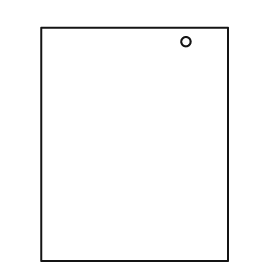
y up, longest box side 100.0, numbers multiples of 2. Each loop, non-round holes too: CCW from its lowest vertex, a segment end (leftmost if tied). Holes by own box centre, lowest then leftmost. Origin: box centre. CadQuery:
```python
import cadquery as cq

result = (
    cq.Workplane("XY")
    .moveTo(-40.0, -50.0)
    .lineTo(40.0, -50.0)
    .lineTo(40.0, 50.0)
    .lineTo(-40.0, 50.0)
    .close()
    .moveTo(22.0, 44.0)
    .circle(2.0)
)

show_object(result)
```